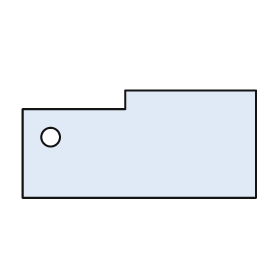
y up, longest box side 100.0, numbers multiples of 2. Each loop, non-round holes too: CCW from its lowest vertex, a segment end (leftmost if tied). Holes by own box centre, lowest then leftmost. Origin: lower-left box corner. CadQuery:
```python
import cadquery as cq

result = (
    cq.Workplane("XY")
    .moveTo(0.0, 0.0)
    .lineTo(100.0, 0.0)
    .lineTo(100.0, 46.0)
    .lineTo(44.0, 46.0)
    .lineTo(44.0, 38.0)
    .lineTo(0.0, 38.0)
    .close()
    .moveTo(12.0, 26.0)
    .circle(4.0)
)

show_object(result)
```